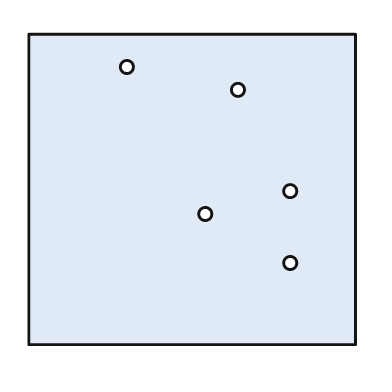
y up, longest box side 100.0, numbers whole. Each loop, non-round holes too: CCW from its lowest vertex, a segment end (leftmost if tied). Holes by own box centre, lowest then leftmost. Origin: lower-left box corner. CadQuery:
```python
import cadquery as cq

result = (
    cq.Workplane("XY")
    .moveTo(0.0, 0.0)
    .lineTo(100.0, 0.0)
    .lineTo(100.0, 95.0)
    .lineTo(0.0, 95.0)
    .close()
    .moveTo(80.0, 25.0)
    .circle(2.0)
    .moveTo(54.0, 40.0)
    .circle(2.0)
    .moveTo(80.0, 47.0)
    .circle(2.0)
    .moveTo(64.0, 78.0)
    .circle(2.0)
    .moveTo(30.0, 85.0)
    .circle(2.0)
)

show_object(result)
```